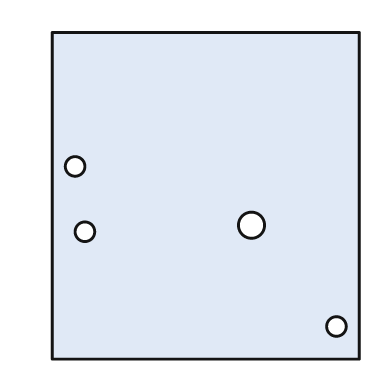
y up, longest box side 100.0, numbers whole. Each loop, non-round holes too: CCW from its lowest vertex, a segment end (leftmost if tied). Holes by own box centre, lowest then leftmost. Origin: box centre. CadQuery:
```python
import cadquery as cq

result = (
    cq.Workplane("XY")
    .moveTo(-47.0, -50.0)
    .lineTo(47.0, -50.0)
    .lineTo(47.0, 50.0)
    .lineTo(-47.0, 50.0)
    .close()
    .moveTo(40.0, -40.0)
    .circle(3.0)
    .moveTo(-37.0, -11.0)
    .circle(3.0)
    .moveTo(14.0, -9.0)
    .circle(4.0)
    .moveTo(-40.0, 9.0)
    .circle(3.0)
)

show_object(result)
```